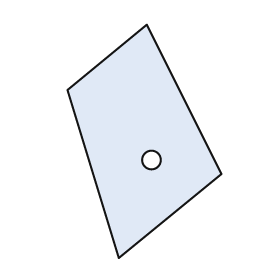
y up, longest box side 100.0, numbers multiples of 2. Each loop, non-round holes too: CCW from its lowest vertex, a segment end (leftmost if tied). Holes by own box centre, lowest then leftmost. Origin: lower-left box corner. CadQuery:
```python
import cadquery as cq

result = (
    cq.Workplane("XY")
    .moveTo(22.0, 0.0)
    .lineTo(66.0, 36.0)
    .lineTo(34.0, 100.0)
    .lineTo(0.0, 72.0)
    .close()
    .moveTo(36.0, 42.0)
    .circle(4.0)
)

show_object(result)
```